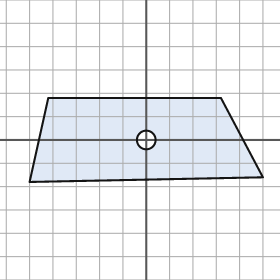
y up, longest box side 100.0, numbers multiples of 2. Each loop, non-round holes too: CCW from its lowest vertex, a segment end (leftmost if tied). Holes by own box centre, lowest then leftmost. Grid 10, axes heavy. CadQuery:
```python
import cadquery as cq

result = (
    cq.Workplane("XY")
    .moveTo(-50.0, -18.0)
    .lineTo(50.0, -16.0)
    .lineTo(32.0, 18.0)
    .lineTo(-42.0, 18.0)
    .close()
    .moveTo(0.0, 0.0)
    .circle(4.0)
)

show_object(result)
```